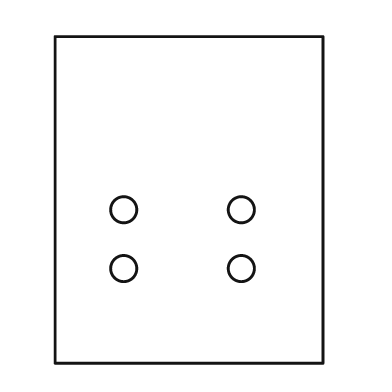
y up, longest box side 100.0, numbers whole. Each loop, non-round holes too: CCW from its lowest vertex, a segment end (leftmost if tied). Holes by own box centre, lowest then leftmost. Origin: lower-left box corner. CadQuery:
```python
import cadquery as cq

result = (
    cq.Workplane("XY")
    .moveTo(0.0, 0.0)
    .lineTo(82.0, 0.0)
    .lineTo(82.0, 100.0)
    .lineTo(0.0, 100.0)
    .close()
    .moveTo(21.0, 29.0)
    .circle(4.0)
    .moveTo(57.0, 29.0)
    .circle(4.0)
    .moveTo(21.0, 47.0)
    .circle(4.0)
    .moveTo(57.0, 47.0)
    .circle(4.0)
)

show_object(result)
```